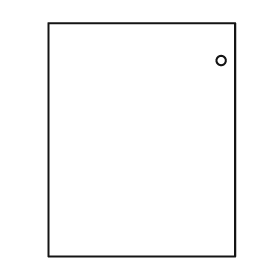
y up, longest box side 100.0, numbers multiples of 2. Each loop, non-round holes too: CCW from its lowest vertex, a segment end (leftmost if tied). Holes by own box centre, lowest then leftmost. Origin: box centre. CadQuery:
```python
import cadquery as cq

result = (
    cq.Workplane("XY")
    .moveTo(-40.0, -50.0)
    .lineTo(40.0, -50.0)
    .lineTo(40.0, 50.0)
    .lineTo(-40.0, 50.0)
    .close()
    .moveTo(34.0, 34.0)
    .circle(2.0)
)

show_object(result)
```